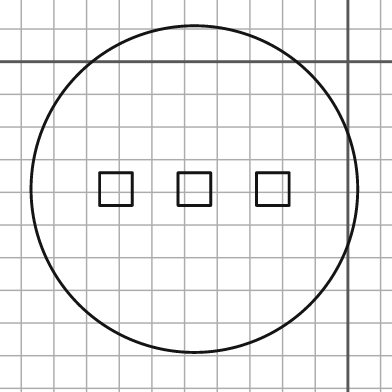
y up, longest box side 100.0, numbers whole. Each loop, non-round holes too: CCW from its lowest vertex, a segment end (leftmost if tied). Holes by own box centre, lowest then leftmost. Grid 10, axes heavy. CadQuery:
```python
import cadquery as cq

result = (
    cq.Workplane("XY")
    .moveTo(-47.0, -39.0)
    .circle(50.0)
    .moveTo(-76.0, -44.0)
    .lineTo(-66.0, -44.0)
    .lineTo(-66.0, -34.0)
    .lineTo(-76.0, -34.0)
    .close()
    .moveTo(-52.0, -44.0)
    .lineTo(-42.0, -44.0)
    .lineTo(-42.0, -34.0)
    .lineTo(-52.0, -34.0)
    .close()
    .moveTo(-28.0, -44.0)
    .lineTo(-18.0, -44.0)
    .lineTo(-18.0, -34.0)
    .lineTo(-28.0, -34.0)
    .close()
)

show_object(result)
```